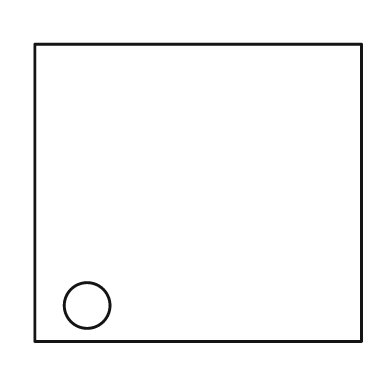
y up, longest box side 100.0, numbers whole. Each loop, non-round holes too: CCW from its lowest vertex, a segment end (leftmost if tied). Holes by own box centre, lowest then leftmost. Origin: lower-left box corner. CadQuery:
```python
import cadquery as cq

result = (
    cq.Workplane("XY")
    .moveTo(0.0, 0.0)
    .lineTo(100.0, 0.0)
    .lineTo(100.0, 91.0)
    .lineTo(0.0, 91.0)
    .close()
    .moveTo(16.0, 11.0)
    .circle(7.0)
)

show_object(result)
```